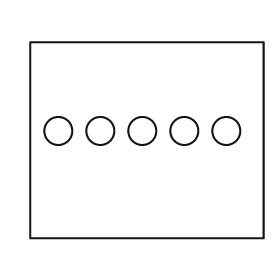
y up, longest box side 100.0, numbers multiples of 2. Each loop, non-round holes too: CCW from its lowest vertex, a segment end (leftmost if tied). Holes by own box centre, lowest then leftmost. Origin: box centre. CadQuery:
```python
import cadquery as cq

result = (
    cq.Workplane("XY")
    .moveTo(-50.0, -42.0)
    .lineTo(50.0, -42.0)
    .lineTo(50.0, 42.0)
    .lineTo(-50.0, 42.0)
    .close()
    .moveTo(-38.0, 4.0)
    .circle(6.0)
    .moveTo(-20.0, 4.0)
    .circle(6.0)
    .moveTo(-2.0, 4.0)
    .circle(6.0)
    .moveTo(16.0, 4.0)
    .circle(6.0)
    .moveTo(34.0, 4.0)
    .circle(6.0)
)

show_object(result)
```